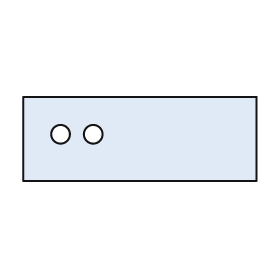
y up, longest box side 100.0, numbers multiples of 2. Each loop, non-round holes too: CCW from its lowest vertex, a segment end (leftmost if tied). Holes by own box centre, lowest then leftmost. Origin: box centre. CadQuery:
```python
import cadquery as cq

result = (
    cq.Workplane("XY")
    .moveTo(-50.0, -18.0)
    .lineTo(50.0, -18.0)
    .lineTo(50.0, 18.0)
    .lineTo(-50.0, 18.0)
    .close()
    .moveTo(-34.0, 2.0)
    .circle(4.0)
    .moveTo(-20.0, 2.0)
    .circle(4.0)
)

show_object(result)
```